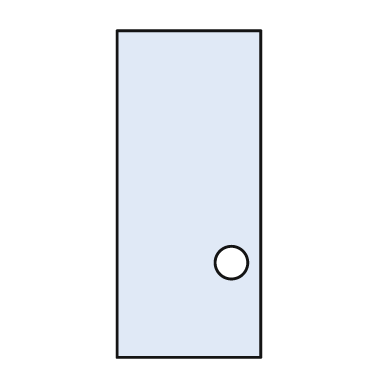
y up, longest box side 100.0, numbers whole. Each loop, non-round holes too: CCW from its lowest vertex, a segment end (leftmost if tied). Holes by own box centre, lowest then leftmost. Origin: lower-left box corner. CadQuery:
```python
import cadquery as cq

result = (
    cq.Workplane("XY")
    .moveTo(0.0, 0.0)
    .lineTo(44.0, 0.0)
    .lineTo(44.0, 100.0)
    .lineTo(0.0, 100.0)
    .close()
    .moveTo(35.0, 29.0)
    .circle(5.0)
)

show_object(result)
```